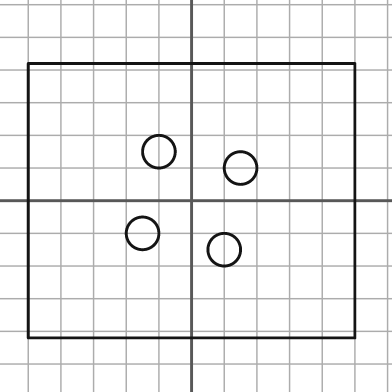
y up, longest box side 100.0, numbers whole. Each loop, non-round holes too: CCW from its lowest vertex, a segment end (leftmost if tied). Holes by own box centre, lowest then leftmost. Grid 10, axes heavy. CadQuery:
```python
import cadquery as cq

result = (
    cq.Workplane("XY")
    .moveTo(-50.0, -42.0)
    .lineTo(50.0, -42.0)
    .lineTo(50.0, 42.0)
    .lineTo(-50.0, 42.0)
    .close()
    .moveTo(10.0, -15.0)
    .circle(5.0)
    .moveTo(-15.0, -10.0)
    .circle(5.0)
    .moveTo(15.0, 10.0)
    .circle(5.0)
    .moveTo(-10.0, 15.0)
    .circle(5.0)
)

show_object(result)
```